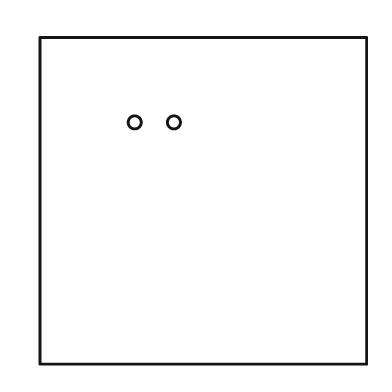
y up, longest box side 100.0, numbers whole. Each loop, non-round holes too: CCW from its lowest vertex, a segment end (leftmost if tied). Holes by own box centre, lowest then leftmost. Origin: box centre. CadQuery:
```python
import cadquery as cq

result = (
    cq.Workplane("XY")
    .moveTo(-50.0, -50.0)
    .lineTo(50.0, -50.0)
    .lineTo(50.0, 50.0)
    .lineTo(-50.0, 50.0)
    .close()
    .moveTo(-21.0, 24.0)
    .circle(2.0)
    .moveTo(-9.0, 24.0)
    .circle(2.0)
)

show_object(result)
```